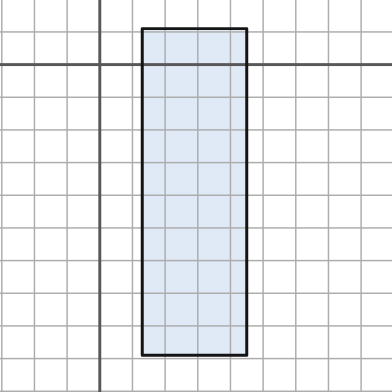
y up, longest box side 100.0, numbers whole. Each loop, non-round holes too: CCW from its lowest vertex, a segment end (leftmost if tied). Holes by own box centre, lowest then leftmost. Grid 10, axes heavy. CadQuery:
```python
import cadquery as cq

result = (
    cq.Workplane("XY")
    .moveTo(13.0, -89.0)
    .lineTo(45.0, -89.0)
    .lineTo(45.0, 11.0)
    .lineTo(13.0, 11.0)
    .close()
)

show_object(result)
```